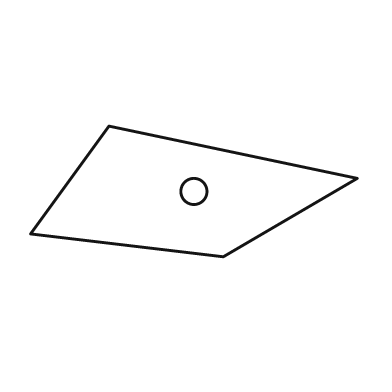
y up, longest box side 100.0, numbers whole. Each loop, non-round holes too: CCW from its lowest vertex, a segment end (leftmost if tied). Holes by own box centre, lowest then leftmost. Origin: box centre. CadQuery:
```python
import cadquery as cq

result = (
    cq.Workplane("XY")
    .moveTo(9.0, -20.0)
    .lineTo(50.0, 4.0)
    .lineTo(-26.0, 20.0)
    .lineTo(-50.0, -13.0)
    .close()
    .moveTo(0.0, 0.0)
    .circle(4.0)
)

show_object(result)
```